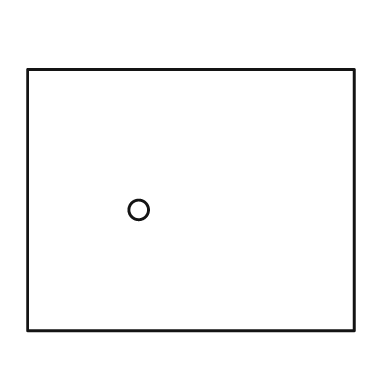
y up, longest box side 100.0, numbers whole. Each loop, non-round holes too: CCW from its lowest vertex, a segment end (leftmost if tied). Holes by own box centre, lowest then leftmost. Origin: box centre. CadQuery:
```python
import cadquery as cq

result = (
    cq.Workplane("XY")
    .moveTo(-50.0, -40.0)
    .lineTo(50.0, -40.0)
    .lineTo(50.0, 40.0)
    .lineTo(-50.0, 40.0)
    .close()
    .moveTo(-16.0, -3.0)
    .circle(3.0)
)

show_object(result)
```